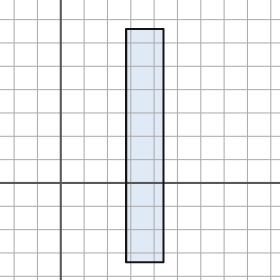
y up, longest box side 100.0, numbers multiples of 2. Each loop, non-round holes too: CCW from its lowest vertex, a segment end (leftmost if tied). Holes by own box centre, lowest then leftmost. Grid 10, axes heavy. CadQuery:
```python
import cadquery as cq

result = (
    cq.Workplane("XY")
    .moveTo(28.0, -34.0)
    .lineTo(44.0, -34.0)
    .lineTo(44.0, 66.0)
    .lineTo(28.0, 66.0)
    .close()
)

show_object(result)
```